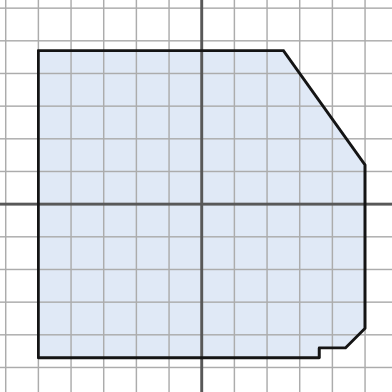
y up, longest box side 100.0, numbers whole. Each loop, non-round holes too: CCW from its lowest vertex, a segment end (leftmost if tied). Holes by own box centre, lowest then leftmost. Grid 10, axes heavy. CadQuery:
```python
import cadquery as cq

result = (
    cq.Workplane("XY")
    .moveTo(-50.0, -47.0)
    .lineTo(36.0, -47.0)
    .lineTo(36.0, -44.0)
    .lineTo(44.0, -44.0)
    .lineTo(50.0, -38.0)
    .lineTo(50.0, 12.0)
    .lineTo(25.0, 47.0)
    .lineTo(-50.0, 47.0)
    .close()
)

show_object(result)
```